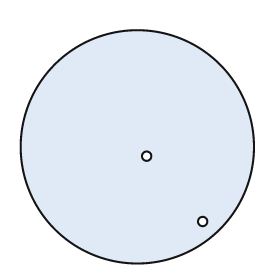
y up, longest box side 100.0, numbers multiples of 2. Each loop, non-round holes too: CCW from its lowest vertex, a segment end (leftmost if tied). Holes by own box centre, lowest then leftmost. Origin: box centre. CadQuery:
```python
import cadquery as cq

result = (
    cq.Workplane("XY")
    .moveTo(0.0, 0.0)
    .circle(50.0)
    .moveTo(28.0, -32.0)
    .circle(2.0)
    .moveTo(4.0, -4.0)
    .circle(2.0)
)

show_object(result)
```